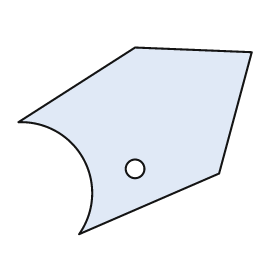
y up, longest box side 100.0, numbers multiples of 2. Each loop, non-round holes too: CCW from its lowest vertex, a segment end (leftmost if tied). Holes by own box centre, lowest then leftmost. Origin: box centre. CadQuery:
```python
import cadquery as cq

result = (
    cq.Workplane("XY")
    .moveTo(-24.0, -40.0)
    .lineTo(36.0, -14.0)
    .lineTo(50.0, 38.0)
    .lineTo(0.0, 40.0)
    .lineTo(-50.0, 8.0)
    .threePointArc((-22.0, -8.0), (-24.0, -40.0))
    .close()
    .moveTo(0.0, -12.0)
    .circle(4.0)
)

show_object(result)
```